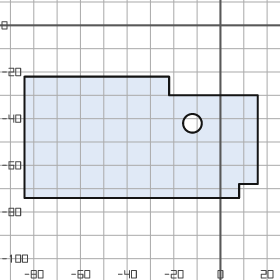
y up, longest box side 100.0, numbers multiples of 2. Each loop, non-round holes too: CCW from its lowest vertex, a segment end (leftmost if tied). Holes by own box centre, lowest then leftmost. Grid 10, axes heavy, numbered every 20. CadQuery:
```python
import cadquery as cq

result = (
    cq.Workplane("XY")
    .moveTo(-84.0, -74.0)
    .lineTo(8.0, -74.0)
    .lineTo(8.0, -68.0)
    .lineTo(16.0, -68.0)
    .lineTo(16.0, -30.0)
    .lineTo(-22.0, -30.0)
    .lineTo(-22.0, -22.0)
    .lineTo(-84.0, -22.0)
    .close()
    .moveTo(-12.0, -42.0)
    .circle(4.0)
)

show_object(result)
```